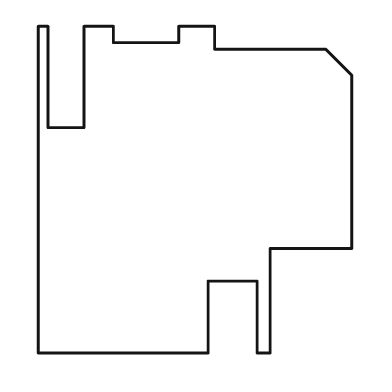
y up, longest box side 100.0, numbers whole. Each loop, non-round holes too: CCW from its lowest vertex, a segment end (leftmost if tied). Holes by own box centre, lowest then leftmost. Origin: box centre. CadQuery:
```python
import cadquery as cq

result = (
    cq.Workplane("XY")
    .moveTo(-48.0, -50.0)
    .lineTo(4.0, -50.0)
    .lineTo(4.0, -28.0)
    .lineTo(19.0, -28.0)
    .lineTo(19.0, -50.0)
    .lineTo(23.0, -50.0)
    .lineTo(23.0, -18.0)
    .lineTo(48.0, -18.0)
    .lineTo(48.0, 35.0)
    .lineTo(40.0, 43.0)
    .lineTo(6.0, 43.0)
    .lineTo(6.0, 50.0)
    .lineTo(-5.0, 50.0)
    .lineTo(-5.0, 45.0)
    .lineTo(-25.0, 45.0)
    .lineTo(-25.0, 50.0)
    .lineTo(-34.0, 50.0)
    .lineTo(-34.0, 19.0)
    .lineTo(-45.0, 19.0)
    .lineTo(-45.0, 50.0)
    .lineTo(-48.0, 50.0)
    .close()
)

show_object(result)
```